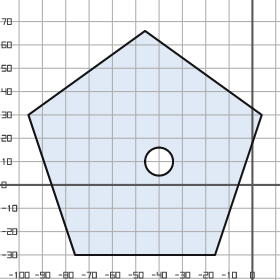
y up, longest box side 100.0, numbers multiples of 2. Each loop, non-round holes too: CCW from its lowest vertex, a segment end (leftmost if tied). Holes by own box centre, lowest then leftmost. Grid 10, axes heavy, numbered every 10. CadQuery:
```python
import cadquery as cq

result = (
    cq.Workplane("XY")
    .moveTo(-76.0, -30.0)
    .lineTo(-16.0, -30.0)
    .lineTo(4.0, 30.0)
    .lineTo(-46.0, 66.0)
    .lineTo(-96.0, 30.0)
    .close()
    .moveTo(-40.0, 10.0)
    .circle(6.0)
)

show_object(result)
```